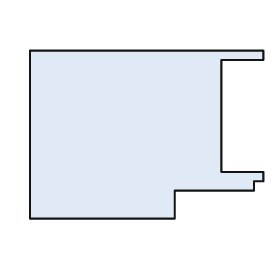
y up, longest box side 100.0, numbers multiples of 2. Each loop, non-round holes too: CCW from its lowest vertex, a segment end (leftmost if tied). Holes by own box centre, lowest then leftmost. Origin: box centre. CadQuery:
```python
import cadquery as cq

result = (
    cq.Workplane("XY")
    .moveTo(-50.0, -36.0)
    .lineTo(12.0, -36.0)
    .lineTo(12.0, -24.0)
    .lineTo(46.0, -24.0)
    .lineTo(46.0, -20.0)
    .lineTo(50.0, -20.0)
    .lineTo(50.0, -16.0)
    .lineTo(32.0, -16.0)
    .lineTo(32.0, 32.0)
    .lineTo(50.0, 32.0)
    .lineTo(50.0, 36.0)
    .lineTo(-50.0, 36.0)
    .close()
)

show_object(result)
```